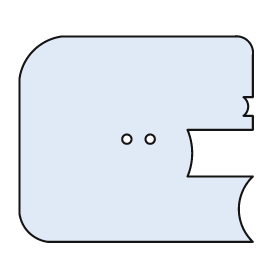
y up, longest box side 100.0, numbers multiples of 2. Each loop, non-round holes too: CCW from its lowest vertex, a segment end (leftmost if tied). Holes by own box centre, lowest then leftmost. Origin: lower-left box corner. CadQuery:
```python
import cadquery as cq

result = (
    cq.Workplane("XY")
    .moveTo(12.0, 0.0)
    .lineTo(100.0, 0.0)
    .threePointArc((94.0, 14.0), (100.0, 28.0))
    .lineTo(72.0, 28.0)
    .threePointArc((74.0, 38.0), (72.0, 48.0))
    .lineTo(100.0, 48.0)
    .lineTo(100.0, 54.0)
    .lineTo(96.0, 54.0)
    .threePointArc((98.0, 58.0), (96.0, 62.0))
    .lineTo(100.0, 62.0)
    .lineTo(100.0, 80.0)
    .threePointArc((98.0, 86.0), (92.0, 88.0))
    .lineTo(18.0, 88.0)
    .threePointArc((6.0, 82.0), (0.0, 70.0))
    .lineTo(0.0, 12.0)
    .threePointArc((4.0, 4.0), (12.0, 0.0))
    .close()
    .moveTo(46.0, 44.0)
    .circle(2.0)
    .moveTo(56.0, 44.0)
    .circle(2.0)
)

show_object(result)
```